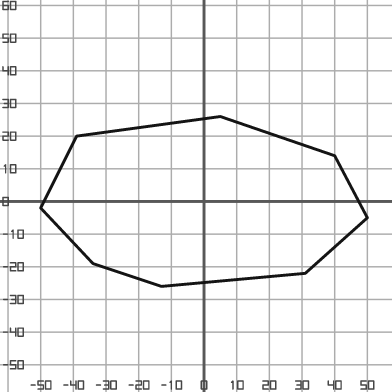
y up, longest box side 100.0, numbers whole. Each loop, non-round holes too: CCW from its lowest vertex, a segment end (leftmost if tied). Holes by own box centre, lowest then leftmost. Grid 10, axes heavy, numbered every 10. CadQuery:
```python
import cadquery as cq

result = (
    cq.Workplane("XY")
    .moveTo(-13.0, -26.0)
    .lineTo(31.0, -22.0)
    .lineTo(50.0, -5.0)
    .lineTo(40.0, 14.0)
    .lineTo(5.0, 26.0)
    .lineTo(-39.0, 20.0)
    .lineTo(-50.0, -2.0)
    .lineTo(-34.0, -19.0)
    .close()
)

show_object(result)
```